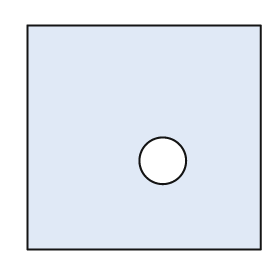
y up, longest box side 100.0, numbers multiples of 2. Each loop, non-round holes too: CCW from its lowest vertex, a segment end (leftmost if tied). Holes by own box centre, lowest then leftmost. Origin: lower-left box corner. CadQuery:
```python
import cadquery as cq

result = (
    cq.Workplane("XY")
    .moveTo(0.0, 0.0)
    .lineTo(100.0, 0.0)
    .lineTo(100.0, 96.0)
    .lineTo(0.0, 96.0)
    .close()
    .moveTo(58.0, 38.0)
    .circle(10.0)
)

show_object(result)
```